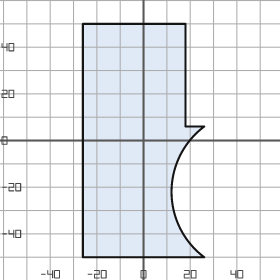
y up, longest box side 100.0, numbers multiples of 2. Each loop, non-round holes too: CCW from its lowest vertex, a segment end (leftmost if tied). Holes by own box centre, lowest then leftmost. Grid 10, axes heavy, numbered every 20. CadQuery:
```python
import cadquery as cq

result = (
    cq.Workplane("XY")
    .moveTo(-26.0, -50.0)
    .lineTo(26.0, -50.0)
    .threePointArc((12.0, -22.0), (26.0, 6.0))
    .lineTo(18.0, 6.0)
    .lineTo(18.0, 50.0)
    .lineTo(-26.0, 50.0)
    .close()
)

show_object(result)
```